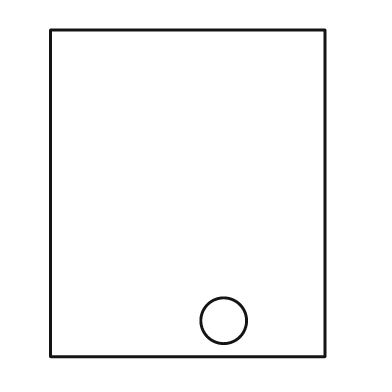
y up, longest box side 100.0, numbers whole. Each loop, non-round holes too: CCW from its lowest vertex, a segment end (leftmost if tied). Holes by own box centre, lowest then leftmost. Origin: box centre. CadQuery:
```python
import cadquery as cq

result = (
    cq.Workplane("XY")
    .moveTo(-42.0, -50.0)
    .lineTo(42.0, -50.0)
    .lineTo(42.0, 50.0)
    .lineTo(-42.0, 50.0)
    .close()
    .moveTo(11.0, -39.0)
    .circle(7.0)
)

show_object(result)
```